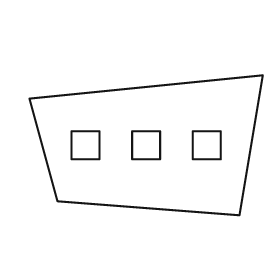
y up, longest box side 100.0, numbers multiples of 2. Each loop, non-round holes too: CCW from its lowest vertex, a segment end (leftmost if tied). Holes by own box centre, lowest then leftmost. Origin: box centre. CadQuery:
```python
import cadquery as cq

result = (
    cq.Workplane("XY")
    .moveTo(40.0, -30.0)
    .lineTo(50.0, 30.0)
    .lineTo(-50.0, 20.0)
    .lineTo(-38.0, -24.0)
    .close()
    .moveTo(-32.0, -6.0)
    .lineTo(-20.0, -6.0)
    .lineTo(-20.0, 6.0)
    .lineTo(-32.0, 6.0)
    .close()
    .moveTo(-6.0, -6.0)
    .lineTo(6.0, -6.0)
    .lineTo(6.0, 6.0)
    .lineTo(-6.0, 6.0)
    .close()
    .moveTo(20.0, -6.0)
    .lineTo(32.0, -6.0)
    .lineTo(32.0, 6.0)
    .lineTo(20.0, 6.0)
    .close()
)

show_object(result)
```